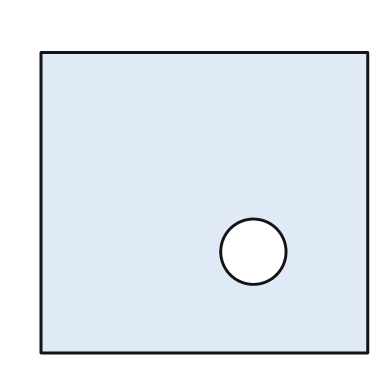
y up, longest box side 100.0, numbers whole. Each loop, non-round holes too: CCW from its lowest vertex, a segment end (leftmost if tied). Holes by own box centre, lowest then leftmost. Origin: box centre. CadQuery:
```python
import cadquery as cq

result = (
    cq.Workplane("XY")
    .moveTo(-50.0, -46.0)
    .lineTo(50.0, -46.0)
    .lineTo(50.0, 46.0)
    .lineTo(-50.0, 46.0)
    .close()
    .moveTo(15.0, -15.0)
    .circle(10.0)
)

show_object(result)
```